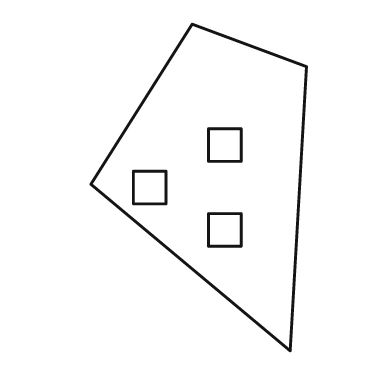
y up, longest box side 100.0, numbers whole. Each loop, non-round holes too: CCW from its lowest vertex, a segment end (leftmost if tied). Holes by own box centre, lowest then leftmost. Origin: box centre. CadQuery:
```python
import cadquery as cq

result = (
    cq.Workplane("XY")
    .moveTo(28.0, -50.0)
    .lineTo(33.0, 37.0)
    .lineTo(-2.0, 50.0)
    .lineTo(-33.0, 1.0)
    .close()
    .moveTo(3.0, -18.0)
    .lineTo(13.0, -18.0)
    .lineTo(13.0, -8.0)
    .lineTo(3.0, -8.0)
    .close()
    .moveTo(-20.0, -5.0)
    .lineTo(-10.0, -5.0)
    .lineTo(-10.0, 5.0)
    .lineTo(-20.0, 5.0)
    .close()
    .moveTo(3.0, 8.0)
    .lineTo(13.0, 8.0)
    .lineTo(13.0, 18.0)
    .lineTo(3.0, 18.0)
    .close()
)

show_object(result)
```